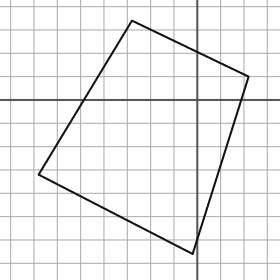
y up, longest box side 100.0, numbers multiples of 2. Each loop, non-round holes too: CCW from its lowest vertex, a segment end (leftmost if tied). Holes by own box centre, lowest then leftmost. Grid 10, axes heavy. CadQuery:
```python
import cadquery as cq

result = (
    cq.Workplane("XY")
    .moveTo(-2.0, -66.0)
    .lineTo(22.0, 10.0)
    .lineTo(-28.0, 34.0)
    .lineTo(-68.0, -32.0)
    .close()
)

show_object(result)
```